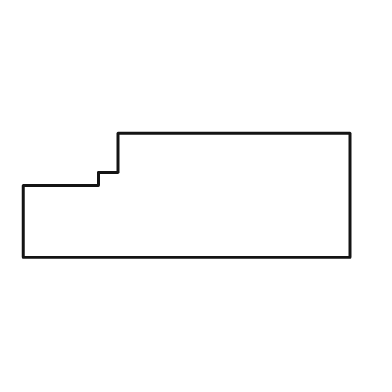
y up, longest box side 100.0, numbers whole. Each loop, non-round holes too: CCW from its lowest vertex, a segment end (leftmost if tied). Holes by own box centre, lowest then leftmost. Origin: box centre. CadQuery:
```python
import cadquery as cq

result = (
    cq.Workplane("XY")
    .moveTo(-50.0, -19.0)
    .lineTo(50.0, -19.0)
    .lineTo(50.0, 19.0)
    .lineTo(-21.0, 19.0)
    .lineTo(-21.0, 7.0)
    .lineTo(-27.0, 7.0)
    .lineTo(-27.0, 3.0)
    .lineTo(-50.0, 3.0)
    .close()
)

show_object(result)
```